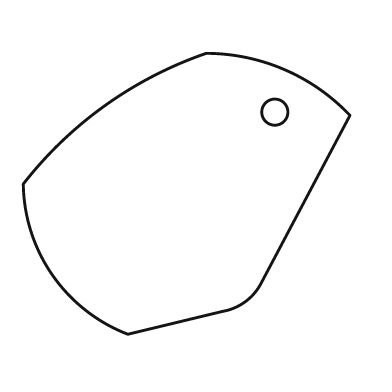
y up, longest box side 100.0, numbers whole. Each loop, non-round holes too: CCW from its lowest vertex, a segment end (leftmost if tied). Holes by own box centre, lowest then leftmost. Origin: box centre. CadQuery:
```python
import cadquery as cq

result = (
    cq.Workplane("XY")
    .moveTo(-18.0, -43.0)
    .lineTo(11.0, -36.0)
    .threePointArc((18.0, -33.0), (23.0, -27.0))
    .lineTo(50.0, 24.0)
    .threePointArc((30.0, 38.0), (6.0, 43.0))
    .threePointArc((-25.0, 27.0), (-50.0, 3.0))
    .threePointArc((-41.0, -25.0), (-18.0, -43.0))
    .close()
    .moveTo(27.0, 25.0)
    .circle(4.0)
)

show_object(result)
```